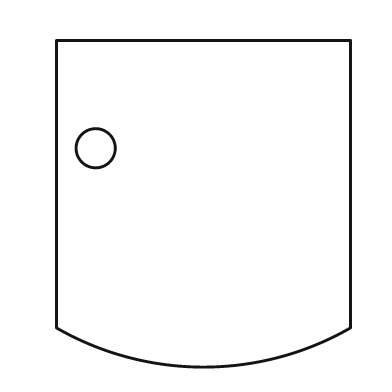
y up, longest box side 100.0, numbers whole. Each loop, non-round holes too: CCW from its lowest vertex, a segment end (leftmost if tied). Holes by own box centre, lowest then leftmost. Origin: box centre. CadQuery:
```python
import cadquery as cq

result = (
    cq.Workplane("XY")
    .moveTo(-45.0, -38.0)
    .threePointArc((0.0, -50.0), (45.0, -38.0))
    .lineTo(45.0, 50.0)
    .lineTo(-45.0, 50.0)
    .close()
    .moveTo(-33.0, 17.0)
    .circle(6.0)
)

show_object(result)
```